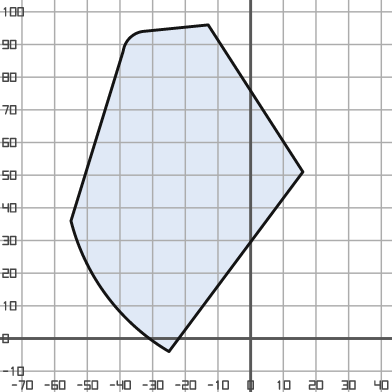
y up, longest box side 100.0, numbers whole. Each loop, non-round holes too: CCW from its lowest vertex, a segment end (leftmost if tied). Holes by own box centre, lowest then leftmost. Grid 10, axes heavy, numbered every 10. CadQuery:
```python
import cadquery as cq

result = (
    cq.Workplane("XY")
    .moveTo(-25.0, -4.0)
    .lineTo(16.0, 51.0)
    .lineTo(-13.0, 96.0)
    .lineTo(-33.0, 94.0)
    .threePointArc((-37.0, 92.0), (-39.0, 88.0))
    .lineTo(-55.0, 36.0)
    .threePointArc((-44.0, 13.0), (-25.0, -4.0))
    .close()
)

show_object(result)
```